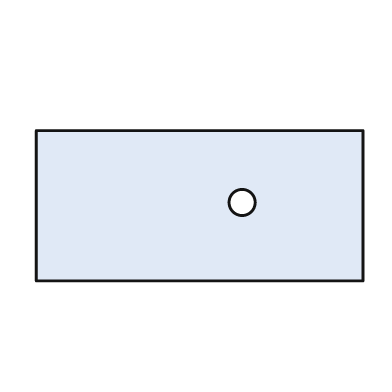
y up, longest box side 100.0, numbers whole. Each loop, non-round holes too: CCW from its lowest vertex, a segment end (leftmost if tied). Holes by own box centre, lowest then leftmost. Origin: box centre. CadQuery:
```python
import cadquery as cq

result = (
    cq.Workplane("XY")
    .moveTo(-50.0, -23.0)
    .lineTo(50.0, -23.0)
    .lineTo(50.0, 23.0)
    .lineTo(-50.0, 23.0)
    .close()
    .moveTo(13.0, 1.0)
    .circle(4.0)
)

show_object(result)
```